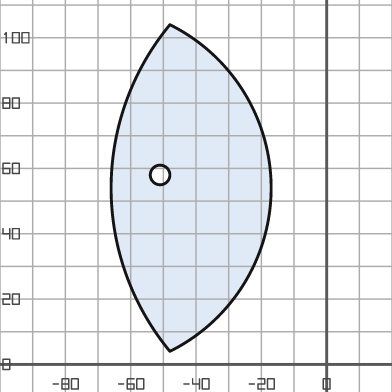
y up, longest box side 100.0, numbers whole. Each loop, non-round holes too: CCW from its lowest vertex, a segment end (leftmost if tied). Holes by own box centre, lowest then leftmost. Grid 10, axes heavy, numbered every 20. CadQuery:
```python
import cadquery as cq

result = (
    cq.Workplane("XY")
    .moveTo(-48.0, 4.0)
    .threePointArc((-17.0, 54.0), (-48.0, 104.0))
    .threePointArc((-66.0, 54.0), (-48.0, 4.0))
    .close()
    .moveTo(-51.0, 58.0)
    .circle(3.0)
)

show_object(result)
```